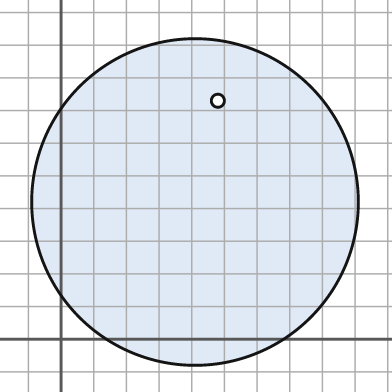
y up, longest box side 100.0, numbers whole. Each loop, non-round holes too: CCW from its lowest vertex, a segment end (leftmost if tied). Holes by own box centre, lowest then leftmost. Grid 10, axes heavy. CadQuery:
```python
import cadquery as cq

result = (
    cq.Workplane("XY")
    .moveTo(41.0, 42.0)
    .circle(50.0)
    .moveTo(48.0, 73.0)
    .circle(2.0)
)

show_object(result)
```